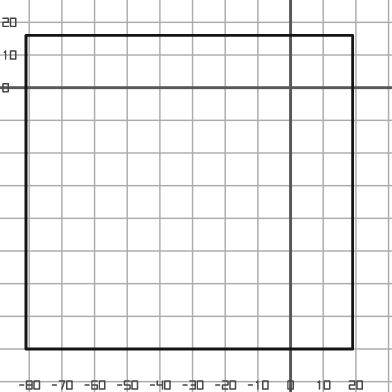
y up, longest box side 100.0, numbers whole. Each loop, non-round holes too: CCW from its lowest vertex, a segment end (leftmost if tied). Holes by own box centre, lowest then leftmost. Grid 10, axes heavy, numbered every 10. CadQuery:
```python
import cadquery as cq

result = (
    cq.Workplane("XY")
    .moveTo(-81.0, -80.0)
    .lineTo(19.0, -80.0)
    .lineTo(19.0, 16.0)
    .lineTo(-81.0, 16.0)
    .close()
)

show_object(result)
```